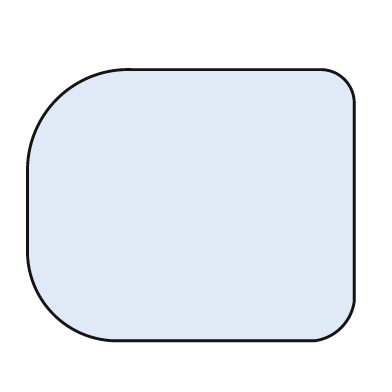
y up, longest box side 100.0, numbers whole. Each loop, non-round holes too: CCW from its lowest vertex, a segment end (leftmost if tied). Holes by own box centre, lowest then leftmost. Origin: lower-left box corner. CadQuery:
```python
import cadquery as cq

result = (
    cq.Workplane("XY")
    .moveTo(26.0, 0.0)
    .lineTo(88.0, 0.0)
    .threePointArc((96.0, 4.0), (100.0, 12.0))
    .lineTo(100.0, 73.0)
    .threePointArc((97.0, 80.0), (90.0, 83.0))
    .lineTo(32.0, 83.0)
    .threePointArc((9.0, 74.0), (0.0, 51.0))
    .lineTo(0.0, 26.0)
    .threePointArc((8.0, 8.0), (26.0, 0.0))
    .close()
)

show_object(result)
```